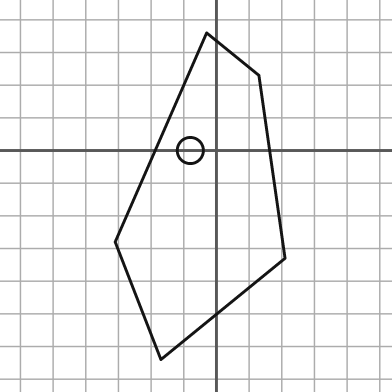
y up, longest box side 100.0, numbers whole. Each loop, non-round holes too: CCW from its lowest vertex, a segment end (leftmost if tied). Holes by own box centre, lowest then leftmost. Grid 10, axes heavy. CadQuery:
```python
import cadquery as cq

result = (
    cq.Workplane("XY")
    .moveTo(-17.0, -64.0)
    .lineTo(21.0, -33.0)
    .lineTo(13.0, 23.0)
    .lineTo(-3.0, 36.0)
    .lineTo(-31.0, -28.0)
    .close()
    .moveTo(-8.0, 0.0)
    .circle(4.0)
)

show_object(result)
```